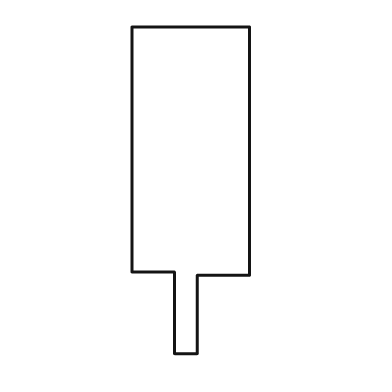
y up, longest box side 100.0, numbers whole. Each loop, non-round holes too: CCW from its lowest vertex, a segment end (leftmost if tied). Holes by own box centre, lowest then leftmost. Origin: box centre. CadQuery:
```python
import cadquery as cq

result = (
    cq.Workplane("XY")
    .moveTo(-5.0, -50.0)
    .lineTo(2.0, -50.0)
    .lineTo(2.0, -26.0)
    .lineTo(18.0, -26.0)
    .lineTo(18.0, 50.0)
    .lineTo(-18.0, 50.0)
    .lineTo(-18.0, -25.0)
    .lineTo(-5.0, -25.0)
    .close()
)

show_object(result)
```